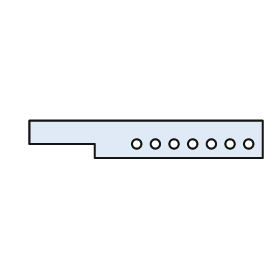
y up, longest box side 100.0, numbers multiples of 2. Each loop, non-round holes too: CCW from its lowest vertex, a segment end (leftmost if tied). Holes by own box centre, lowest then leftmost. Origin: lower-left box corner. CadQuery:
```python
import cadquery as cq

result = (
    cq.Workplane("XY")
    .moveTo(28.0, 0.0)
    .lineTo(100.0, 0.0)
    .lineTo(100.0, 16.0)
    .lineTo(0.0, 16.0)
    .lineTo(0.0, 6.0)
    .lineTo(28.0, 6.0)
    .close()
    .moveTo(46.0, 6.0)
    .circle(2.0)
    .moveTo(54.0, 6.0)
    .circle(2.0)
    .moveTo(62.0, 6.0)
    .circle(2.0)
    .moveTo(70.0, 6.0)
    .circle(2.0)
    .moveTo(78.0, 6.0)
    .circle(2.0)
    .moveTo(86.0, 6.0)
    .circle(2.0)
    .moveTo(94.0, 6.0)
    .circle(2.0)
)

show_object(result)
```